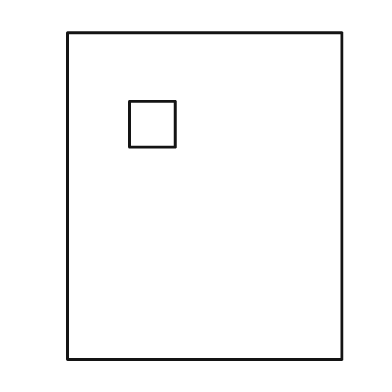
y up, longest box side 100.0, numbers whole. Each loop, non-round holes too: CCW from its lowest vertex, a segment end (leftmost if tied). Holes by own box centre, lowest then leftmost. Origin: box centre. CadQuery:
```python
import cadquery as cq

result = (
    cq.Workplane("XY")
    .moveTo(-42.0, -50.0)
    .lineTo(42.0, -50.0)
    .lineTo(42.0, 50.0)
    .lineTo(-42.0, 50.0)
    .close()
    .moveTo(-23.0, 15.0)
    .lineTo(-9.0, 15.0)
    .lineTo(-9.0, 29.0)
    .lineTo(-23.0, 29.0)
    .close()
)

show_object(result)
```